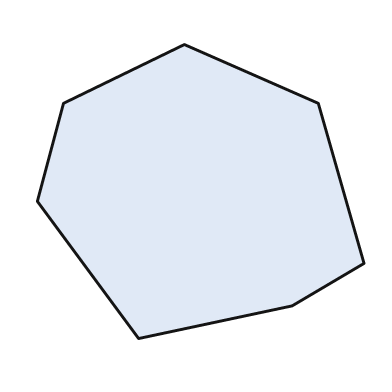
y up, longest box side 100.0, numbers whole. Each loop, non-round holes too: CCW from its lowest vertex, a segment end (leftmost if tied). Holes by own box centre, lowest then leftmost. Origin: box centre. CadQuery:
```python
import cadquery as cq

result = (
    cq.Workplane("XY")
    .moveTo(-19.0, -45.0)
    .lineTo(28.0, -35.0)
    .lineTo(50.0, -22.0)
    .lineTo(36.0, 27.0)
    .lineTo(-5.0, 45.0)
    .lineTo(-42.0, 27.0)
    .lineTo(-50.0, -3.0)
    .close()
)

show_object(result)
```